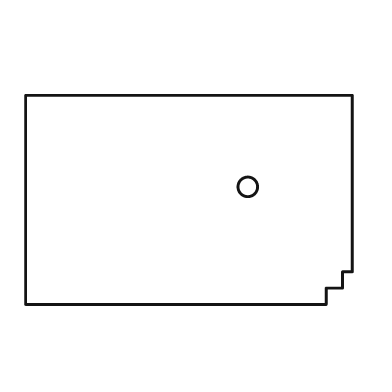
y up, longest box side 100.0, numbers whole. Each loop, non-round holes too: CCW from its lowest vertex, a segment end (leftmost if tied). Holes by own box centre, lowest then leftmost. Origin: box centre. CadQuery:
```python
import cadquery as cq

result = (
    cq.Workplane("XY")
    .moveTo(-50.0, -32.0)
    .lineTo(42.0, -32.0)
    .lineTo(42.0, -27.0)
    .lineTo(47.0, -27.0)
    .lineTo(47.0, -22.0)
    .lineTo(50.0, -22.0)
    .lineTo(50.0, 32.0)
    .lineTo(-50.0, 32.0)
    .close()
    .moveTo(18.0, 4.0)
    .circle(3.0)
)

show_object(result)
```